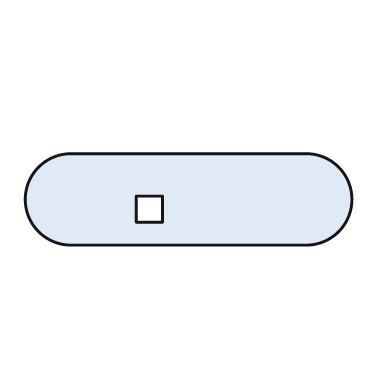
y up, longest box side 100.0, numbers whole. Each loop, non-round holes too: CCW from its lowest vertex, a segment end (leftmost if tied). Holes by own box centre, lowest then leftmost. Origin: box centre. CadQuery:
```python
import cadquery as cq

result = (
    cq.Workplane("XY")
    .moveTo(-36.0, -14.0)
    .lineTo(36.0, -14.0)
    .threePointArc((50.0, 0.0), (36.0, 14.0))
    .lineTo(-36.0, 14.0)
    .threePointArc((-50.0, 0.0), (-36.0, -14.0))
    .close()
    .moveTo(-16.0, -7.0)
    .lineTo(-8.0, -7.0)
    .lineTo(-8.0, 1.0)
    .lineTo(-16.0, 1.0)
    .close()
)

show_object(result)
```